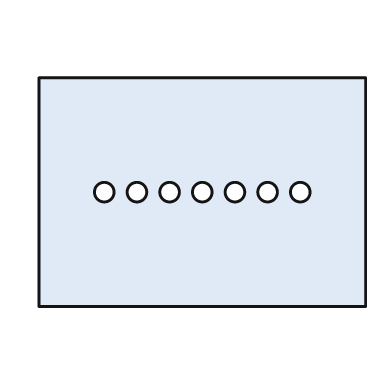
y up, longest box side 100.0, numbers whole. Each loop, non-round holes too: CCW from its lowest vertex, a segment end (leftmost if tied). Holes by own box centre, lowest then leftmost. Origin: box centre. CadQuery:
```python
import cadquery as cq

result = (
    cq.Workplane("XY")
    .moveTo(-50.0, -35.0)
    .lineTo(50.0, -35.0)
    .lineTo(50.0, 35.0)
    .lineTo(-50.0, 35.0)
    .close()
    .moveTo(-30.0, 0.0)
    .circle(3.0)
    .moveTo(-20.0, 0.0)
    .circle(3.0)
    .moveTo(-10.0, 0.0)
    .circle(3.0)
    .moveTo(0.0, 0.0)
    .circle(3.0)
    .moveTo(10.0, 0.0)
    .circle(3.0)
    .moveTo(20.0, 0.0)
    .circle(3.0)
    .moveTo(30.0, 0.0)
    .circle(3.0)
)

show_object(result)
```